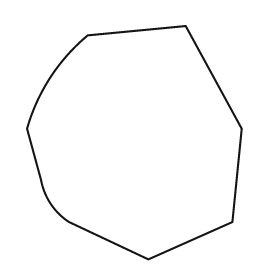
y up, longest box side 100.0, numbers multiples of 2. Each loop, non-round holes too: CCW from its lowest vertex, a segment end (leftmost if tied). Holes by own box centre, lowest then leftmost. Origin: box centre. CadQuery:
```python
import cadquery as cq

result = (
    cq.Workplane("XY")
    .moveTo(6.0, -50.0)
    .lineTo(42.0, -34.0)
    .lineTo(46.0, 6.0)
    .lineTo(22.0, 50.0)
    .lineTo(-20.0, 46.0)
    .threePointArc((-36.0, 28.0), (-46.0, 6.0))
    .lineTo(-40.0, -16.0)
    .threePointArc((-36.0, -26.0), (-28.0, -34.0))
    .close()
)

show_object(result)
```